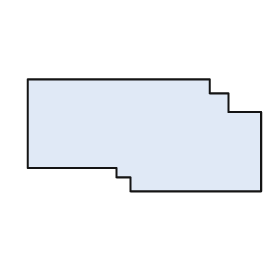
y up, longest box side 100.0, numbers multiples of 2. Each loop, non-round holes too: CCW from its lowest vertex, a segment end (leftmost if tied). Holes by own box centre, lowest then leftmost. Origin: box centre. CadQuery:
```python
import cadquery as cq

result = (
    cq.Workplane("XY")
    .moveTo(-6.0, -24.0)
    .lineTo(50.0, -24.0)
    .lineTo(50.0, 10.0)
    .lineTo(36.0, 10.0)
    .lineTo(36.0, 18.0)
    .lineTo(28.0, 18.0)
    .lineTo(28.0, 24.0)
    .lineTo(-50.0, 24.0)
    .lineTo(-50.0, -14.0)
    .lineTo(-12.0, -14.0)
    .lineTo(-12.0, -18.0)
    .lineTo(-6.0, -18.0)
    .close()
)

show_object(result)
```